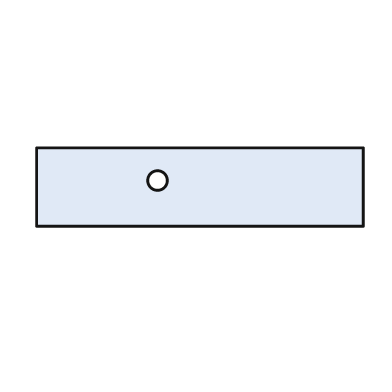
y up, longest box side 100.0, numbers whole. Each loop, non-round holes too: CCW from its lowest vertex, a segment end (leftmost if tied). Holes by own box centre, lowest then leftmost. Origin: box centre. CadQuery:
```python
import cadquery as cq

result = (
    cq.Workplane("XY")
    .moveTo(-50.0, -12.0)
    .lineTo(50.0, -12.0)
    .lineTo(50.0, 12.0)
    .lineTo(-50.0, 12.0)
    .close()
    .moveTo(-13.0, 2.0)
    .circle(3.0)
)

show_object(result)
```